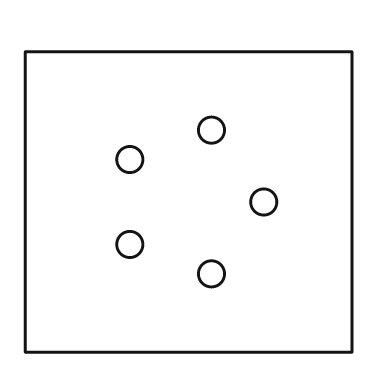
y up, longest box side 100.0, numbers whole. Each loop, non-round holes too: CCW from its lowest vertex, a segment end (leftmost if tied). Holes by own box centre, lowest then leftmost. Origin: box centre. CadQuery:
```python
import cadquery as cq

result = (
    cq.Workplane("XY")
    .moveTo(-50.0, -46.0)
    .lineTo(50.0, -46.0)
    .lineTo(50.0, 46.0)
    .lineTo(-50.0, 46.0)
    .close()
    .moveTo(7.0, -22.0)
    .circle(4.0)
    .moveTo(-18.0, -13.0)
    .circle(4.0)
    .moveTo(23.0, 0.0)
    .circle(4.0)
    .moveTo(-18.0, 13.0)
    .circle(4.0)
    .moveTo(7.0, 22.0)
    .circle(4.0)
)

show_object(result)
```